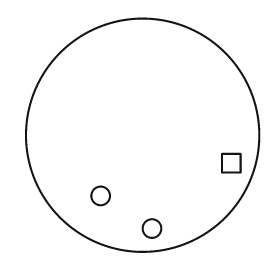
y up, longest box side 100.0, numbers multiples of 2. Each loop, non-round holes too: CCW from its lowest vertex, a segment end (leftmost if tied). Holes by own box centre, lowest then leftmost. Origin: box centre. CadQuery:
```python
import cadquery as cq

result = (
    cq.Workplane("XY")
    .moveTo(0.0, 0.0)
    .circle(50.0)
    .moveTo(4.0, -40.0)
    .circle(4.0)
    .moveTo(-18.0, -26.0)
    .circle(4.0)
    .moveTo(34.0, -16.0)
    .lineTo(42.0, -16.0)
    .lineTo(42.0, -8.0)
    .lineTo(34.0, -8.0)
    .close()
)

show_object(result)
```